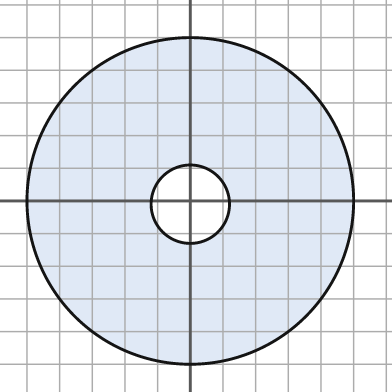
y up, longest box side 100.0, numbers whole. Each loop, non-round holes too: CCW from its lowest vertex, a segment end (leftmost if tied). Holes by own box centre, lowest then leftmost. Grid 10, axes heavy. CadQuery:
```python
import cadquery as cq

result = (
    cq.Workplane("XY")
    .moveTo(0.0, 0.0)
    .circle(50.0)
    .moveTo(0.0, -1.0)
    .circle(12.0)
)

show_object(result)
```